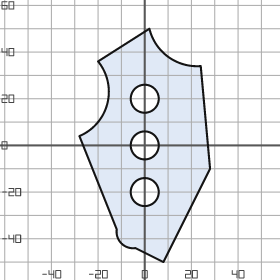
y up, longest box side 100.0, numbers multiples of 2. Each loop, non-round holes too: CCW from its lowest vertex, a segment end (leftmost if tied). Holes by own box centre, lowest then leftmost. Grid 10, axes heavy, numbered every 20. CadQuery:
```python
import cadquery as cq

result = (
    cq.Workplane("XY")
    .moveTo(8.0, -50.0)
    .lineTo(28.0, -10.0)
    .lineTo(24.0, 34.0)
    .threePointArc((10.0, 38.0), (2.0, 50.0))
    .lineTo(-20.0, 36.0)
    .threePointArc((-16.0, 18.0), (-28.0, 4.0))
    .lineTo(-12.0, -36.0)
    .threePointArc((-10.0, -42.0), (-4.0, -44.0))
    .close()
    .moveTo(0.0, -20.0)
    .circle(6.0)
    .moveTo(0.0, 0.0)
    .circle(6.0)
    .moveTo(0.0, 20.0)
    .circle(6.0)
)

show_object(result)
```